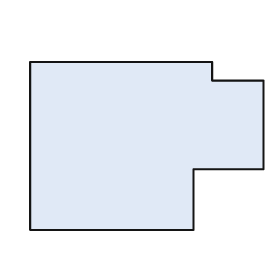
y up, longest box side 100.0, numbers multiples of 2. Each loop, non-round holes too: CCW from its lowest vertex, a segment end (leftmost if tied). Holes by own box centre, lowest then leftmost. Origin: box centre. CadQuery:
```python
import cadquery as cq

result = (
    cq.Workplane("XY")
    .moveTo(-50.0, -36.0)
    .lineTo(20.0, -36.0)
    .lineTo(20.0, -10.0)
    .lineTo(50.0, -10.0)
    .lineTo(50.0, 28.0)
    .lineTo(28.0, 28.0)
    .lineTo(28.0, 36.0)
    .lineTo(-50.0, 36.0)
    .close()
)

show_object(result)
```